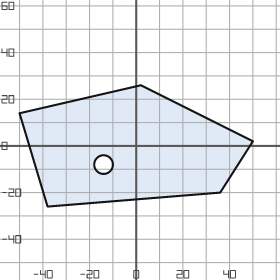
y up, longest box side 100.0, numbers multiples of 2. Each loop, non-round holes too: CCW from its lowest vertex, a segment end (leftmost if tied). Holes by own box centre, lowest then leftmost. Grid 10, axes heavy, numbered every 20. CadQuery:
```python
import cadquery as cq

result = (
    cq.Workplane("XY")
    .moveTo(-38.0, -26.0)
    .lineTo(36.0, -20.0)
    .lineTo(50.0, 2.0)
    .lineTo(2.0, 26.0)
    .lineTo(-50.0, 14.0)
    .close()
    .moveTo(-14.0, -8.0)
    .circle(4.0)
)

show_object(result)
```